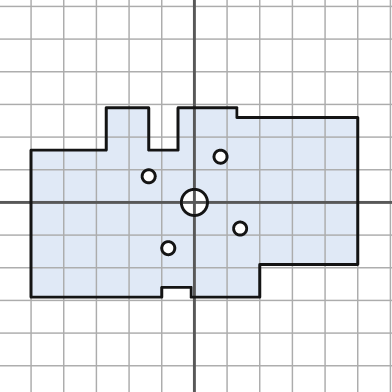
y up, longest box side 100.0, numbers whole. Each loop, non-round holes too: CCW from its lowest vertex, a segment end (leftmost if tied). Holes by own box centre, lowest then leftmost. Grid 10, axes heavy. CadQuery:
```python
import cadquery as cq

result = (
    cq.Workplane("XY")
    .moveTo(-50.0, -29.0)
    .lineTo(-10.0, -29.0)
    .lineTo(-10.0, -26.0)
    .lineTo(-1.0, -26.0)
    .lineTo(-1.0, -29.0)
    .lineTo(20.0, -29.0)
    .lineTo(20.0, -19.0)
    .lineTo(50.0, -19.0)
    .lineTo(50.0, 26.0)
    .lineTo(13.0, 26.0)
    .lineTo(13.0, 29.0)
    .lineTo(-5.0, 29.0)
    .lineTo(-5.0, 16.0)
    .lineTo(-14.0, 16.0)
    .lineTo(-14.0, 29.0)
    .lineTo(-27.0, 29.0)
    .lineTo(-27.0, 16.0)
    .lineTo(-50.0, 16.0)
    .close()
    .moveTo(-8.0, -14.0)
    .circle(2.0)
    .moveTo(14.0, -8.0)
    .circle(2.0)
    .moveTo(0.0, 0.0)
    .circle(4.0)
    .moveTo(-14.0, 8.0)
    .circle(2.0)
    .moveTo(8.0, 14.0)
    .circle(2.0)
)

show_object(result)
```